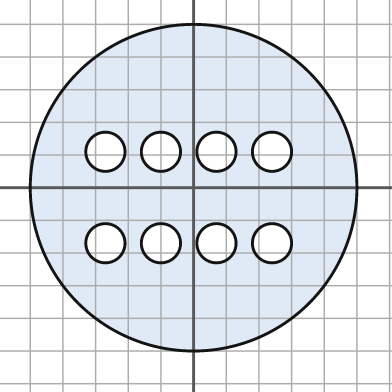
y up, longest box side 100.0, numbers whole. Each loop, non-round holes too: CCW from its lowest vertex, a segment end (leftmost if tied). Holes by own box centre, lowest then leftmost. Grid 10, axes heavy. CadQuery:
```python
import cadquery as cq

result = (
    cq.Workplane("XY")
    .moveTo(0.0, 0.0)
    .circle(50.0)
    .moveTo(-27.0, -17.0)
    .circle(6.0)
    .moveTo(-10.0, -17.0)
    .circle(6.0)
    .moveTo(7.0, -17.0)
    .circle(6.0)
    .moveTo(24.0, -17.0)
    .circle(6.0)
    .moveTo(-27.0, 11.0)
    .circle(6.0)
    .moveTo(-10.0, 11.0)
    .circle(6.0)
    .moveTo(7.0, 11.0)
    .circle(6.0)
    .moveTo(24.0, 11.0)
    .circle(6.0)
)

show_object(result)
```